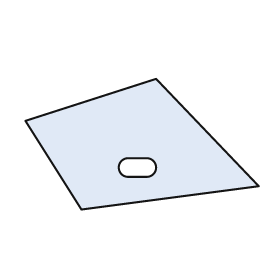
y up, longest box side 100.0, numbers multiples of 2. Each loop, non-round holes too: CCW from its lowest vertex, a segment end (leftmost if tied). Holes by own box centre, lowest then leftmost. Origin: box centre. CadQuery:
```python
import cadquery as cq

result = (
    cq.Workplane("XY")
    .moveTo(-26.0, -28.0)
    .lineTo(50.0, -18.0)
    .lineTo(6.0, 28.0)
    .lineTo(-50.0, 10.0)
    .close()
    .moveTo(-6.0, -14.0)
    .lineTo(2.0, -14.0)
    .threePointArc((6.0, -10.0), (2.0, -6.0))
    .lineTo(-6.0, -6.0)
    .threePointArc((-10.0, -10.0), (-6.0, -14.0))
    .close()
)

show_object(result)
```